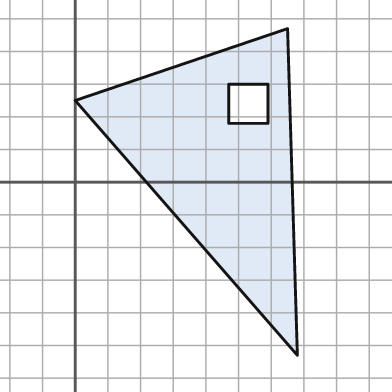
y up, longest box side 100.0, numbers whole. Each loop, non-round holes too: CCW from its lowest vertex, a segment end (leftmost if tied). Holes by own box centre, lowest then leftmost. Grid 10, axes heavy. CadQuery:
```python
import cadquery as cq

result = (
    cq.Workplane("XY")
    .moveTo(68.0, -53.0)
    .lineTo(65.0, 47.0)
    .lineTo(0.0, 25.0)
    .close()
    .moveTo(47.0, 18.0)
    .lineTo(59.0, 18.0)
    .lineTo(59.0, 30.0)
    .lineTo(47.0, 30.0)
    .close()
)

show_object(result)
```